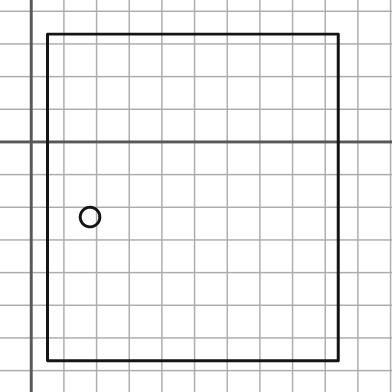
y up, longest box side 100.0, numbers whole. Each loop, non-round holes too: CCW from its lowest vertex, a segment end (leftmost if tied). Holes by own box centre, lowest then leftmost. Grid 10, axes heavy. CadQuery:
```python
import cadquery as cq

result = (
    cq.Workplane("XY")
    .moveTo(5.0, -67.0)
    .lineTo(94.0, -67.0)
    .lineTo(94.0, 33.0)
    .lineTo(5.0, 33.0)
    .close()
    .moveTo(18.0, -23.0)
    .circle(3.0)
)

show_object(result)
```